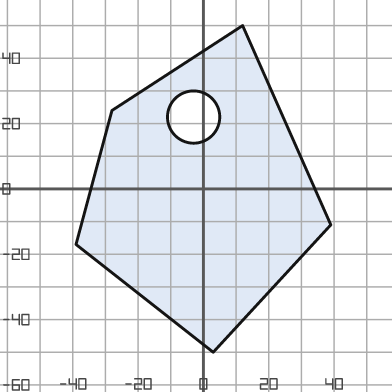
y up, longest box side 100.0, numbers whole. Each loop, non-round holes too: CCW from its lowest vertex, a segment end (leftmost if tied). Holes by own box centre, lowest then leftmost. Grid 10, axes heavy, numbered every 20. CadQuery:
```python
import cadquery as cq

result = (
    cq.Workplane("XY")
    .moveTo(3.0, -50.0)
    .lineTo(39.0, -11.0)
    .lineTo(12.0, 50.0)
    .lineTo(-28.0, 24.0)
    .lineTo(-39.0, -17.0)
    .close()
    .moveTo(-3.0, 22.0)
    .circle(8.0)
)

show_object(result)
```